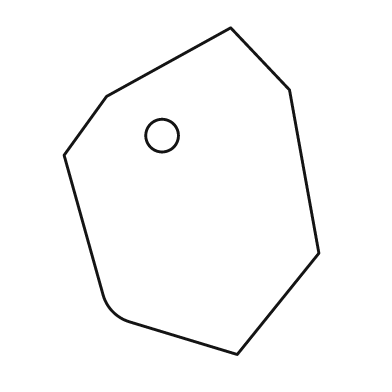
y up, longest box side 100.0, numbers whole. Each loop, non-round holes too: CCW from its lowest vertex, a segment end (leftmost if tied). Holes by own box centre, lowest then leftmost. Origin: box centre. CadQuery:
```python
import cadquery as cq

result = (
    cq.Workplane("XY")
    .moveTo(14.0, -50.0)
    .lineTo(39.0, -19.0)
    .lineTo(30.0, 31.0)
    .lineTo(12.0, 50.0)
    .lineTo(-26.0, 29.0)
    .lineTo(-39.0, 11.0)
    .lineTo(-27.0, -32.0)
    .threePointArc((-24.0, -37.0), (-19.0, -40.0))
    .close()
    .moveTo(-9.0, 17.0)
    .circle(5.0)
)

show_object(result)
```